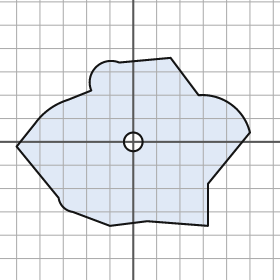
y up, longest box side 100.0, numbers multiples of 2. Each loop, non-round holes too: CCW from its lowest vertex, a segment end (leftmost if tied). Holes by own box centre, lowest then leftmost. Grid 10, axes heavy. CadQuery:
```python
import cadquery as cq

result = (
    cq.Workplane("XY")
    .moveTo(-10.0, -36.0)
    .lineTo(6.0, -34.0)
    .lineTo(32.0, -36.0)
    .lineTo(32.0, -18.0)
    .lineTo(50.0, 4.0)
    .threePointArc((42.0, 16.0), (28.0, 20.0))
    .lineTo(16.0, 36.0)
    .lineTo(-6.0, 34.0)
    .threePointArc((-16.0, 32.0), (-18.0, 22.0))
    .lineTo(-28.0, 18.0)
    .threePointArc((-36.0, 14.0), (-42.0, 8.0))
    .lineTo(-50.0, -2.0)
    .lineTo(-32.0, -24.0)
    .threePointArc((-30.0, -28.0), (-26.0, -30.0))
    .close()
    .moveTo(0.0, 0.0)
    .circle(4.0)
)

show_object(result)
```